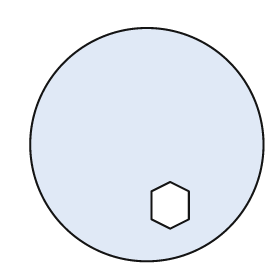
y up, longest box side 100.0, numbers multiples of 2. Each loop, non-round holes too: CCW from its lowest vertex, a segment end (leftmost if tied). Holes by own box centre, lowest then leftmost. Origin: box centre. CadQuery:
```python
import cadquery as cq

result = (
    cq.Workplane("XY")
    .moveTo(0.0, 0.0)
    .circle(50.0)
    .moveTo(10.0, -36.0)
    .lineTo(18.0, -32.0)
    .lineTo(18.0, -20.0)
    .lineTo(10.0, -16.0)
    .lineTo(2.0, -20.0)
    .lineTo(2.0, -32.0)
    .close()
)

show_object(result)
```